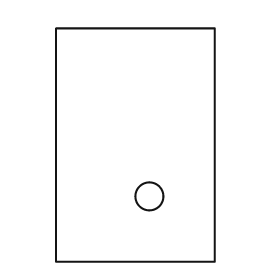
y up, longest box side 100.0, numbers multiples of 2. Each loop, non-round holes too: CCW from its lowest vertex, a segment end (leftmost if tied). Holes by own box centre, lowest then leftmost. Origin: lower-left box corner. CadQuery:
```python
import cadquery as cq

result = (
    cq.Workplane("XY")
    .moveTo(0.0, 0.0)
    .lineTo(68.0, 0.0)
    .lineTo(68.0, 100.0)
    .lineTo(0.0, 100.0)
    .close()
    .moveTo(40.0, 28.0)
    .circle(6.0)
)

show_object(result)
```